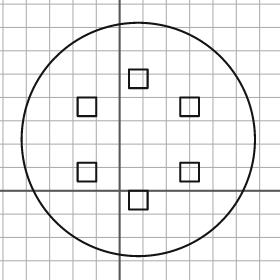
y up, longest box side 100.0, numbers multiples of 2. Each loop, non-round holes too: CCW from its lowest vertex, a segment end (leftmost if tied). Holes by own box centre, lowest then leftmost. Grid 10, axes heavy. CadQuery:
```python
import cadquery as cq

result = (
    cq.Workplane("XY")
    .moveTo(8.0, 22.0)
    .circle(50.0)
    .moveTo(4.0, -8.0)
    .lineTo(12.0, -8.0)
    .lineTo(12.0, 0.0)
    .lineTo(4.0, 0.0)
    .close()
    .moveTo(-18.0, 4.0)
    .lineTo(-10.0, 4.0)
    .lineTo(-10.0, 12.0)
    .lineTo(-18.0, 12.0)
    .close()
    .moveTo(26.0, 4.0)
    .lineTo(34.0, 4.0)
    .lineTo(34.0, 12.0)
    .lineTo(26.0, 12.0)
    .close()
    .moveTo(-18.0, 32.0)
    .lineTo(-10.0, 32.0)
    .lineTo(-10.0, 40.0)
    .lineTo(-18.0, 40.0)
    .close()
    .moveTo(26.0, 32.0)
    .lineTo(34.0, 32.0)
    .lineTo(34.0, 40.0)
    .lineTo(26.0, 40.0)
    .close()
    .moveTo(4.0, 44.0)
    .lineTo(12.0, 44.0)
    .lineTo(12.0, 52.0)
    .lineTo(4.0, 52.0)
    .close()
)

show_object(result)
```